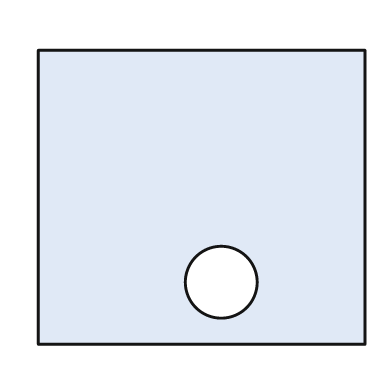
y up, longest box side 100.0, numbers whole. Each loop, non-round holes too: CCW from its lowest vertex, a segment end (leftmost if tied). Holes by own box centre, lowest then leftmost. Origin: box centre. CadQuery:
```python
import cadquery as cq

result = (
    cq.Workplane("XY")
    .moveTo(-50.0, -45.0)
    .lineTo(50.0, -45.0)
    .lineTo(50.0, 45.0)
    .lineTo(-50.0, 45.0)
    .close()
    .moveTo(6.0, -26.0)
    .circle(11.0)
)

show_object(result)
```